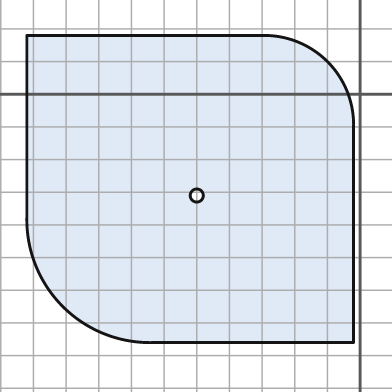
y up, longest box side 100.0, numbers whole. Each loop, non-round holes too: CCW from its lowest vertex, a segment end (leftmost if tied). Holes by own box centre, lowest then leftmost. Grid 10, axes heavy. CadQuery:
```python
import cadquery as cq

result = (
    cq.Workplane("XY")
    .moveTo(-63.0, -76.0)
    .lineTo(-2.0, -76.0)
    .lineTo(-2.0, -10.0)
    .threePointArc((-10.0, 10.0), (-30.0, 18.0))
    .lineTo(-102.0, 18.0)
    .lineTo(-102.0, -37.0)
    .threePointArc((-91.0, -65.0), (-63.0, -76.0))
    .close()
    .moveTo(-50.0, -31.0)
    .circle(2.0)
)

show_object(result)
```